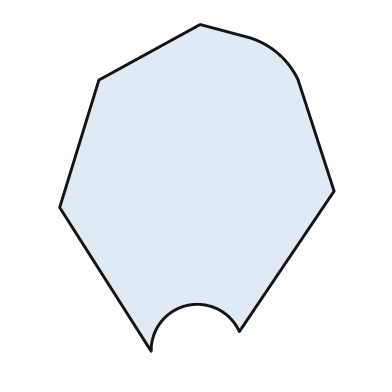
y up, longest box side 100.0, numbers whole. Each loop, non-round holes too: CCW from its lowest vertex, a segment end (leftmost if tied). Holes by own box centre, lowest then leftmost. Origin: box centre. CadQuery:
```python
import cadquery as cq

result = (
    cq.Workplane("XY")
    .moveTo(-14.0, -50.0)
    .threePointArc((-3.0, -36.0), (13.0, -44.0))
    .lineTo(42.0, -1.0)
    .lineTo(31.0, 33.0)
    .threePointArc((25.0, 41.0), (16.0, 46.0))
    .lineTo(1.0, 50.0)
    .lineTo(-30.0, 33.0)
    .lineTo(-42.0, -6.0)
    .close()
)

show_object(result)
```